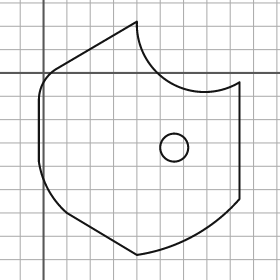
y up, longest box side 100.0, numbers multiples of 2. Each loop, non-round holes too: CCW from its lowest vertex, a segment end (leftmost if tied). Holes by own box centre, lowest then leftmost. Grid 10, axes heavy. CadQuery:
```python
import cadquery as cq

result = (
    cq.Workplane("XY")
    .moveTo(40.0, -78.0)
    .threePointArc((64.0, -70.0), (84.0, -54.0))
    .lineTo(84.0, -4.0)
    .threePointArc((54.0, -4.0), (40.0, 22.0))
    .lineTo(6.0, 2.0)
    .threePointArc((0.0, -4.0), (-2.0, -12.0))
    .lineTo(-2.0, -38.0)
    .threePointArc((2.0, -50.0), (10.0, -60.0))
    .close()
    .moveTo(56.0, -32.0)
    .circle(6.0)
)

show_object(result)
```